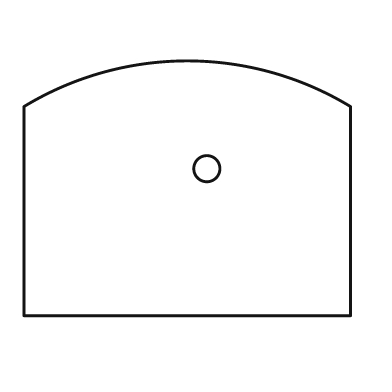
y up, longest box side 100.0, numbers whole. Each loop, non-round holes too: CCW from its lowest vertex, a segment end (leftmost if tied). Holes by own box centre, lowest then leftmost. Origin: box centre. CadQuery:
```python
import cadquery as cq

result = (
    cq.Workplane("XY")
    .moveTo(-50.0, -39.0)
    .lineTo(50.0, -39.0)
    .lineTo(50.0, 25.0)
    .threePointArc((0.0, 39.0), (-50.0, 25.0))
    .close()
    .moveTo(6.0, 6.0)
    .circle(4.0)
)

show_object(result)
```